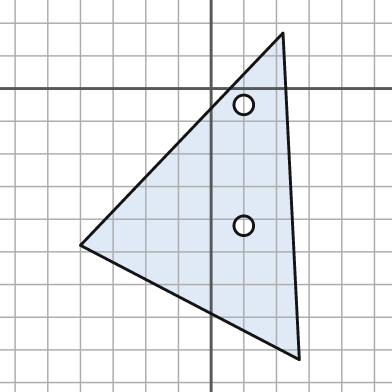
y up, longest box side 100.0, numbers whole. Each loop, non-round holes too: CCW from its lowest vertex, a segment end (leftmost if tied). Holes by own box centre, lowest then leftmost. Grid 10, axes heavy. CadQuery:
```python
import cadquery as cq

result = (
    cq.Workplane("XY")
    .moveTo(27.0, -83.0)
    .lineTo(22.0, 17.0)
    .lineTo(-40.0, -48.0)
    .close()
    .moveTo(10.0, -42.0)
    .circle(3.0)
    .moveTo(10.0, -5.0)
    .circle(3.0)
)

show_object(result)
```